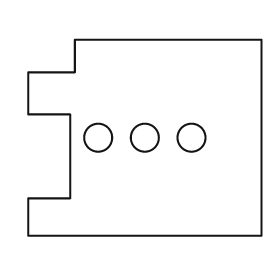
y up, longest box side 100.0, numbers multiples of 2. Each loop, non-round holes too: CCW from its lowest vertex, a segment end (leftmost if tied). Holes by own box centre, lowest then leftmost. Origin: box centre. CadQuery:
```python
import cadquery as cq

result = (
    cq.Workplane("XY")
    .moveTo(-50.0, -42.0)
    .lineTo(50.0, -42.0)
    .lineTo(50.0, 42.0)
    .lineTo(-30.0, 42.0)
    .lineTo(-30.0, 28.0)
    .lineTo(-50.0, 28.0)
    .lineTo(-50.0, 10.0)
    .lineTo(-32.0, 10.0)
    .lineTo(-32.0, -26.0)
    .lineTo(-50.0, -26.0)
    .close()
    .moveTo(-20.0, 0.0)
    .circle(6.0)
    .moveTo(0.0, 0.0)
    .circle(6.0)
    .moveTo(20.0, 0.0)
    .circle(6.0)
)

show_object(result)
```